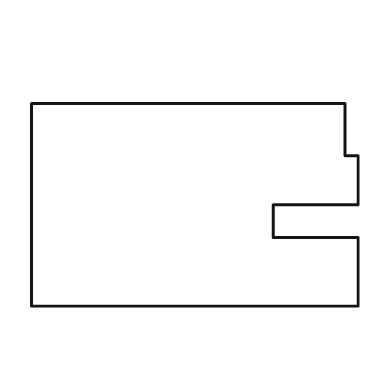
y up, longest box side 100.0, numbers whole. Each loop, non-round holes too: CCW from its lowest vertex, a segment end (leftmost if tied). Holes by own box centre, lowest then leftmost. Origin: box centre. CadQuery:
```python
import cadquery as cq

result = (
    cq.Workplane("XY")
    .moveTo(-50.0, -31.0)
    .lineTo(50.0, -31.0)
    .lineTo(50.0, -10.0)
    .lineTo(24.0, -10.0)
    .lineTo(24.0, 0.0)
    .lineTo(50.0, 0.0)
    .lineTo(50.0, 15.0)
    .lineTo(46.0, 15.0)
    .lineTo(46.0, 31.0)
    .lineTo(-50.0, 31.0)
    .close()
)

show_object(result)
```